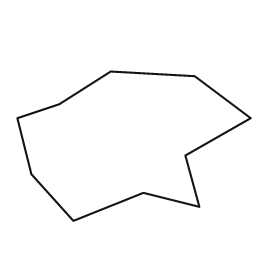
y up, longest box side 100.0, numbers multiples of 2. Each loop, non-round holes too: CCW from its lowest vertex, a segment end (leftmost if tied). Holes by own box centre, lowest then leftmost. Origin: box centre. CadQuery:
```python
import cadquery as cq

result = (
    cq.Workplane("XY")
    .moveTo(-26.0, -32.0)
    .lineTo(4.0, -20.0)
    .lineTo(28.0, -26.0)
    .lineTo(22.0, -4.0)
    .lineTo(50.0, 12.0)
    .lineTo(26.0, 30.0)
    .lineTo(-10.0, 32.0)
    .lineTo(-32.0, 18.0)
    .lineTo(-50.0, 12.0)
    .lineTo(-44.0, -12.0)
    .close()
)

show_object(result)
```